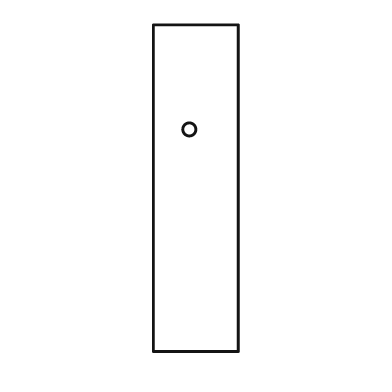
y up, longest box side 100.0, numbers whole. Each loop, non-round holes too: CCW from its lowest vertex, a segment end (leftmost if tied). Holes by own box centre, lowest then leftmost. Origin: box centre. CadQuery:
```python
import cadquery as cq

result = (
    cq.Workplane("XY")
    .moveTo(-13.0, -50.0)
    .lineTo(13.0, -50.0)
    .lineTo(13.0, 50.0)
    .lineTo(-13.0, 50.0)
    .close()
    .moveTo(-2.0, 18.0)
    .circle(2.0)
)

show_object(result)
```